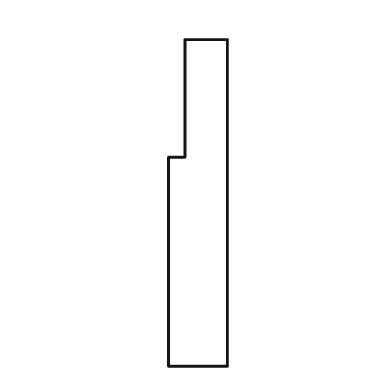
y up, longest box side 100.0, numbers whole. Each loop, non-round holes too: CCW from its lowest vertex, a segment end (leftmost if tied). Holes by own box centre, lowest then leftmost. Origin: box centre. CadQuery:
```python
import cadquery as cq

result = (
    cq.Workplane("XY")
    .moveTo(-9.0, -50.0)
    .lineTo(9.0, -50.0)
    .lineTo(9.0, 50.0)
    .lineTo(-4.0, 50.0)
    .lineTo(-4.0, 14.0)
    .lineTo(-9.0, 14.0)
    .close()
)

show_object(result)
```